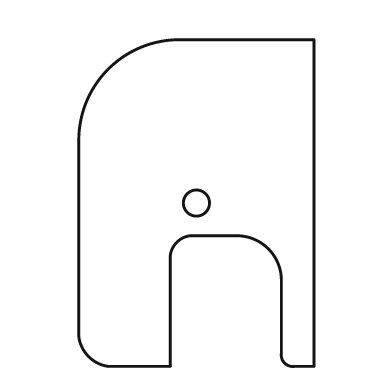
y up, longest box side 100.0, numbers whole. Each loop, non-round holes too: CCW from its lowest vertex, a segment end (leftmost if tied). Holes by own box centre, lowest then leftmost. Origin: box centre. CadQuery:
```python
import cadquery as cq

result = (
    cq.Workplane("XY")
    .moveTo(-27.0, -50.0)
    .lineTo(-8.0, -50.0)
    .lineTo(-8.0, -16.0)
    .threePointArc((-6.0, -12.0), (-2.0, -10.0))
    .lineTo(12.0, -10.0)
    .threePointArc((22.0, -14.0), (26.0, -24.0))
    .lineTo(26.0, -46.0)
    .threePointArc((27.0, -49.0), (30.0, -50.0))
    .lineTo(36.0, -50.0)
    .lineTo(36.0, 50.0)
    .lineTo(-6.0, 50.0)
    .threePointArc((-27.0, 41.0), (-36.0, 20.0))
    .lineTo(-36.0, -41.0)
    .threePointArc((-33.0, -47.0), (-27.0, -50.0))
    .close()
    .moveTo(0.0, 0.0)
    .circle(4.0)
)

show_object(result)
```